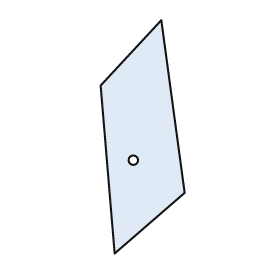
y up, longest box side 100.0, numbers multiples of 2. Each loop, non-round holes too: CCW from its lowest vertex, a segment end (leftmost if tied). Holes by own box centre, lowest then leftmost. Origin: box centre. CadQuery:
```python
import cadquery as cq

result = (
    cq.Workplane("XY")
    .moveTo(-12.0, -50.0)
    .lineTo(18.0, -24.0)
    .lineTo(8.0, 50.0)
    .lineTo(-18.0, 22.0)
    .close()
    .moveTo(-4.0, -10.0)
    .circle(2.0)
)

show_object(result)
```